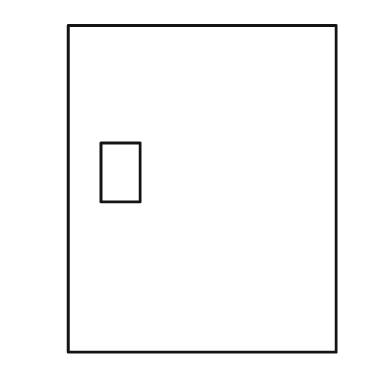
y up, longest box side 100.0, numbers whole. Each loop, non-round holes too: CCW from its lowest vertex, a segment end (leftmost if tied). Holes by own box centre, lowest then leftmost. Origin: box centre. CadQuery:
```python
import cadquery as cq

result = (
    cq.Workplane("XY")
    .moveTo(-41.0, -50.0)
    .lineTo(41.0, -50.0)
    .lineTo(41.0, 50.0)
    .lineTo(-41.0, 50.0)
    .close()
    .moveTo(-31.0, -4.0)
    .lineTo(-19.0, -4.0)
    .lineTo(-19.0, 14.0)
    .lineTo(-31.0, 14.0)
    .close()
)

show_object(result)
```